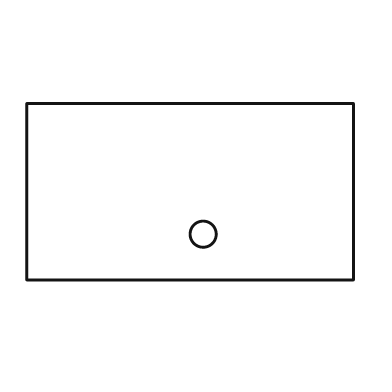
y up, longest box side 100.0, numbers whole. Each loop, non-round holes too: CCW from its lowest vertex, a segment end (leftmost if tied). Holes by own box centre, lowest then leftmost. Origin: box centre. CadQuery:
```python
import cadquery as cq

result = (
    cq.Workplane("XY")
    .moveTo(-50.0, -27.0)
    .lineTo(50.0, -27.0)
    .lineTo(50.0, 27.0)
    .lineTo(-50.0, 27.0)
    .close()
    .moveTo(4.0, -13.0)
    .circle(4.0)
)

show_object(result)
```